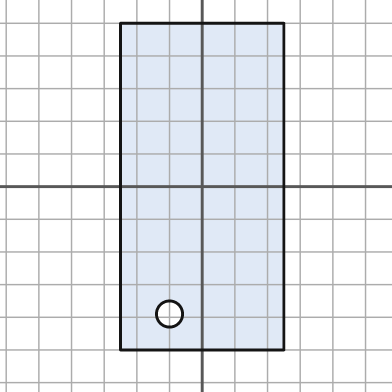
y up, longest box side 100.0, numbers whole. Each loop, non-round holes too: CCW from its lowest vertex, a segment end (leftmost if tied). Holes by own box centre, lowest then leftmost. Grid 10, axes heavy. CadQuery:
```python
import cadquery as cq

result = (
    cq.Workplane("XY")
    .moveTo(-25.0, -50.0)
    .lineTo(25.0, -50.0)
    .lineTo(25.0, 50.0)
    .lineTo(-25.0, 50.0)
    .close()
    .moveTo(-10.0, -39.0)
    .circle(4.0)
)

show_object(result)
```